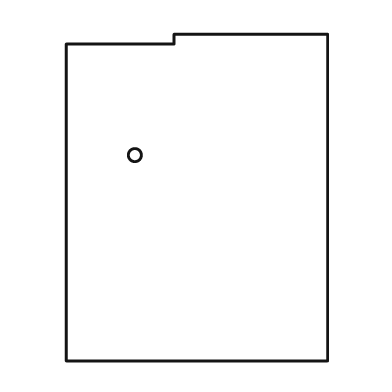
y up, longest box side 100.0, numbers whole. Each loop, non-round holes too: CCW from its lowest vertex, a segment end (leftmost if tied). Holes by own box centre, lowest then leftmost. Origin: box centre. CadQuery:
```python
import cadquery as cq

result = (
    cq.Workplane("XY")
    .moveTo(-40.0, -50.0)
    .lineTo(40.0, -50.0)
    .lineTo(40.0, 50.0)
    .lineTo(-7.0, 50.0)
    .lineTo(-7.0, 47.0)
    .lineTo(-40.0, 47.0)
    .close()
    .moveTo(-19.0, 13.0)
    .circle(2.0)
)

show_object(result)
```